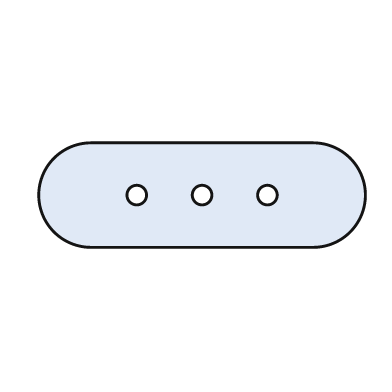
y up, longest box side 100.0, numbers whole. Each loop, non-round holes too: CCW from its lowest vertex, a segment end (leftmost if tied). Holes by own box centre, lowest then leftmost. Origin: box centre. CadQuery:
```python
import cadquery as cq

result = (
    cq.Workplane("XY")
    .moveTo(-34.0, -16.0)
    .lineTo(34.0, -16.0)
    .threePointArc((50.0, 0.0), (34.0, 16.0))
    .lineTo(-34.0, 16.0)
    .threePointArc((-50.0, 0.0), (-34.0, -16.0))
    .close()
    .moveTo(-20.0, 0.0)
    .circle(3.0)
    .moveTo(0.0, 0.0)
    .circle(3.0)
    .moveTo(20.0, 0.0)
    .circle(3.0)
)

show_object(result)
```